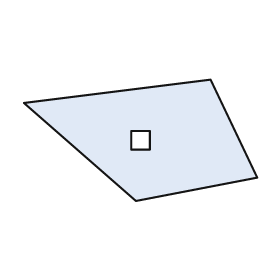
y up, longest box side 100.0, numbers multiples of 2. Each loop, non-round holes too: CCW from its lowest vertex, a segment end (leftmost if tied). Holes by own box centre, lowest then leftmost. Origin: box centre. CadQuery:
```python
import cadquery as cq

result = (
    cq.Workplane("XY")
    .moveTo(-2.0, -26.0)
    .lineTo(50.0, -16.0)
    .lineTo(30.0, 26.0)
    .lineTo(-50.0, 16.0)
    .close()
    .moveTo(-4.0, -4.0)
    .lineTo(4.0, -4.0)
    .lineTo(4.0, 4.0)
    .lineTo(-4.0, 4.0)
    .close()
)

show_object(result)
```